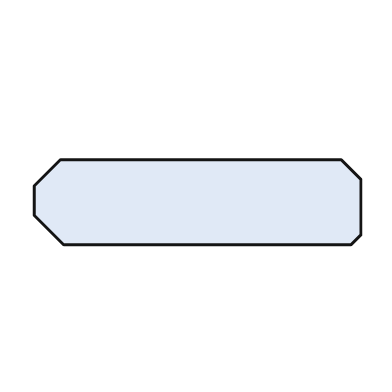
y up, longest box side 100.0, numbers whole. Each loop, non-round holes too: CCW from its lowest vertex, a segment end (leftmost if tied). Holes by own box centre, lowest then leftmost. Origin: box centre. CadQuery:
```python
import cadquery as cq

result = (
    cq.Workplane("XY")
    .moveTo(-41.0, -13.0)
    .lineTo(47.0, -13.0)
    .lineTo(50.0, -10.0)
    .lineTo(50.0, 7.0)
    .lineTo(44.0, 13.0)
    .lineTo(-42.0, 13.0)
    .lineTo(-50.0, 5.0)
    .lineTo(-50.0, -4.0)
    .close()
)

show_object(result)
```